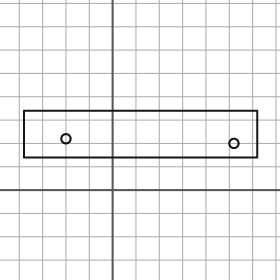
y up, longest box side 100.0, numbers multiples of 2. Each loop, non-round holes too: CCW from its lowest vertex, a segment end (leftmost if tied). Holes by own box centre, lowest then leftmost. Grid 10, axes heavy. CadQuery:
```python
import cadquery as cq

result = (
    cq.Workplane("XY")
    .moveTo(-38.0, 14.0)
    .lineTo(62.0, 14.0)
    .lineTo(62.0, 34.0)
    .lineTo(-38.0, 34.0)
    .close()
    .moveTo(52.0, 20.0)
    .circle(2.0)
    .moveTo(-20.0, 22.0)
    .circle(2.0)
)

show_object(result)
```